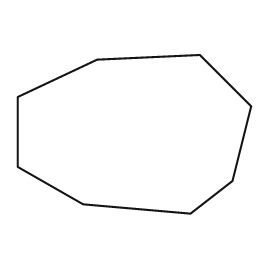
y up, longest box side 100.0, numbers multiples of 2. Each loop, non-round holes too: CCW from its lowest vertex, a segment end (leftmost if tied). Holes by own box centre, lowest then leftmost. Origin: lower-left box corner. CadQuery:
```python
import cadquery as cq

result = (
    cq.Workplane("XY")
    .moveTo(74.0, 0.0)
    .lineTo(92.0, 14.0)
    .lineTo(100.0, 46.0)
    .lineTo(78.0, 68.0)
    .lineTo(34.0, 66.0)
    .lineTo(0.0, 50.0)
    .lineTo(0.0, 20.0)
    .lineTo(28.0, 4.0)
    .close()
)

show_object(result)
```